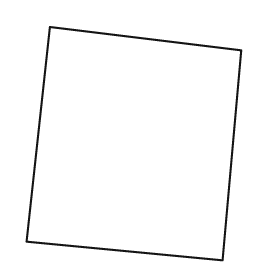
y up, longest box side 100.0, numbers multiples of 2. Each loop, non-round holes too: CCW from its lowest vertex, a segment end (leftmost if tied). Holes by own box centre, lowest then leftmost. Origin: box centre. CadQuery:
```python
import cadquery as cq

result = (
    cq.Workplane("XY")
    .moveTo(38.0, -50.0)
    .lineTo(46.0, 40.0)
    .lineTo(-36.0, 50.0)
    .lineTo(-46.0, -42.0)
    .close()
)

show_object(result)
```